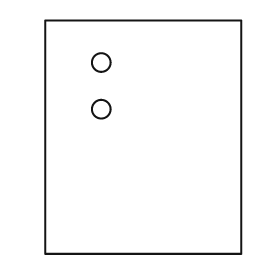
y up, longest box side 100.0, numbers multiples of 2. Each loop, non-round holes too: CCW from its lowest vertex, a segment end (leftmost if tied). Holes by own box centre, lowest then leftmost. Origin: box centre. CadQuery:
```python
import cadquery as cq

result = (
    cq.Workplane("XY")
    .moveTo(-42.0, -50.0)
    .lineTo(42.0, -50.0)
    .lineTo(42.0, 50.0)
    .lineTo(-42.0, 50.0)
    .close()
    .moveTo(-18.0, 12.0)
    .circle(4.0)
    .moveTo(-18.0, 32.0)
    .circle(4.0)
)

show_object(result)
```